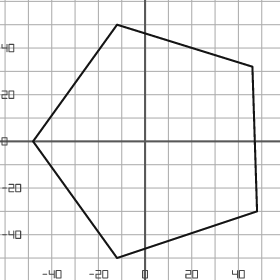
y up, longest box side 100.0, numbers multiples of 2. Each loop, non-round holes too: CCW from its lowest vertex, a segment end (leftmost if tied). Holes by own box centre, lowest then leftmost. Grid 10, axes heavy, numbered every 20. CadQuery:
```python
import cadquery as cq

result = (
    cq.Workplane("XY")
    .moveTo(-12.0, -50.0)
    .lineTo(48.0, -30.0)
    .lineTo(46.0, 32.0)
    .lineTo(-12.0, 50.0)
    .lineTo(-48.0, 0.0)
    .close()
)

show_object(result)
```